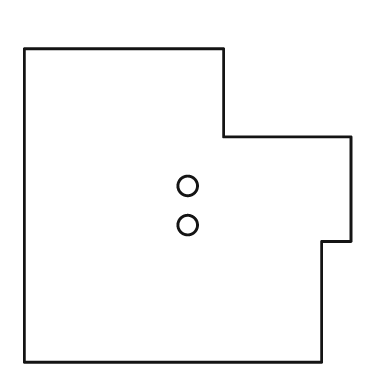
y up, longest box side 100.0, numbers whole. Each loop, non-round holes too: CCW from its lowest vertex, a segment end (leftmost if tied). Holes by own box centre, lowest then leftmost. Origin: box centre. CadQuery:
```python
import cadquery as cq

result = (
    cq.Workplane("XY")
    .moveTo(-50.0, -48.0)
    .lineTo(41.0, -48.0)
    .lineTo(41.0, -11.0)
    .lineTo(50.0, -11.0)
    .lineTo(50.0, 21.0)
    .lineTo(11.0, 21.0)
    .lineTo(11.0, 48.0)
    .lineTo(-50.0, 48.0)
    .close()
    .moveTo(0.0, -6.0)
    .circle(3.0)
    .moveTo(0.0, 6.0)
    .circle(3.0)
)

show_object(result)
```